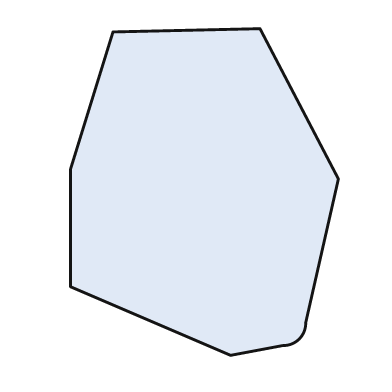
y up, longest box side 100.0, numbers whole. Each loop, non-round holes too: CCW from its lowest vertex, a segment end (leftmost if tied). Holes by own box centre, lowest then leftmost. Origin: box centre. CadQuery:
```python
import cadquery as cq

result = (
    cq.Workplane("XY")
    .moveTo(8.0, -50.0)
    .lineTo(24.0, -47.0)
    .threePointArc((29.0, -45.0), (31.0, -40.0))
    .lineTo(41.0, 4.0)
    .lineTo(17.0, 50.0)
    .lineTo(-28.0, 49.0)
    .lineTo(-41.0, 7.0)
    .lineTo(-41.0, -29.0)
    .close()
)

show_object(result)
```